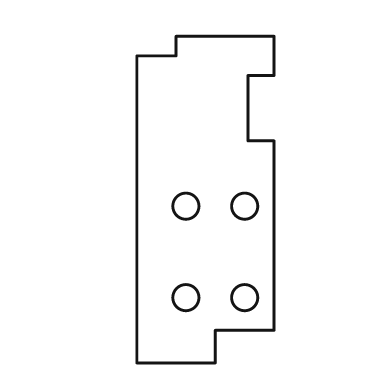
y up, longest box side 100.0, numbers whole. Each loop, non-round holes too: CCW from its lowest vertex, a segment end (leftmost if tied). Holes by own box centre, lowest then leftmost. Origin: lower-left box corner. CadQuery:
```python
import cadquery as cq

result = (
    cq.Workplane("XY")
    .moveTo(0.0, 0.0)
    .lineTo(24.0, 0.0)
    .lineTo(24.0, 10.0)
    .lineTo(42.0, 10.0)
    .lineTo(42.0, 68.0)
    .lineTo(34.0, 68.0)
    .lineTo(34.0, 88.0)
    .lineTo(42.0, 88.0)
    .lineTo(42.0, 100.0)
    .lineTo(12.0, 100.0)
    .lineTo(12.0, 94.0)
    .lineTo(0.0, 94.0)
    .close()
    .moveTo(15.0, 20.0)
    .circle(4.0)
    .moveTo(33.0, 20.0)
    .circle(4.0)
    .moveTo(15.0, 48.0)
    .circle(4.0)
    .moveTo(33.0, 48.0)
    .circle(4.0)
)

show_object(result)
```